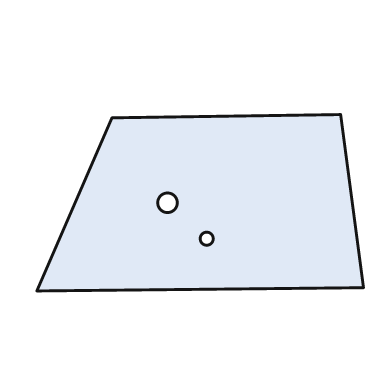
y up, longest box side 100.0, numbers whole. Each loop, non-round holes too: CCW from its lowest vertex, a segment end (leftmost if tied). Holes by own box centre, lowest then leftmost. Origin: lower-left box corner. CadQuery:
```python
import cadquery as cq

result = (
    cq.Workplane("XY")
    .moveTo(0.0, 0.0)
    .lineTo(100.0, 1.0)
    .lineTo(93.0, 54.0)
    .lineTo(23.0, 53.0)
    .close()
    .moveTo(52.0, 16.0)
    .circle(2.0)
    .moveTo(40.0, 27.0)
    .circle(3.0)
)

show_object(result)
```